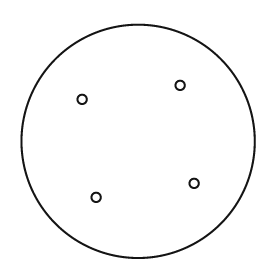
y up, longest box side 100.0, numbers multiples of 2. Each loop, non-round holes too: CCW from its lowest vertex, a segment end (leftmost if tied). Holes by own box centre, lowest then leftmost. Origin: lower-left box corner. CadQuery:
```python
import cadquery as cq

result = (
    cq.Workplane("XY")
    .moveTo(50.0, 50.0)
    .circle(50.0)
    .moveTo(32.0, 26.0)
    .circle(2.0)
    .moveTo(74.0, 32.0)
    .circle(2.0)
    .moveTo(26.0, 68.0)
    .circle(2.0)
    .moveTo(68.0, 74.0)
    .circle(2.0)
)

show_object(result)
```